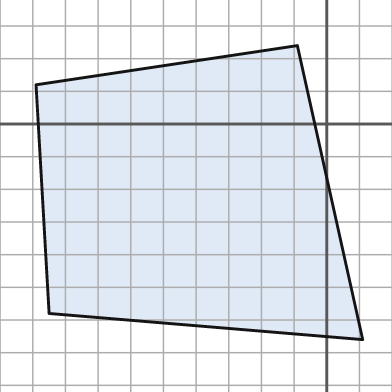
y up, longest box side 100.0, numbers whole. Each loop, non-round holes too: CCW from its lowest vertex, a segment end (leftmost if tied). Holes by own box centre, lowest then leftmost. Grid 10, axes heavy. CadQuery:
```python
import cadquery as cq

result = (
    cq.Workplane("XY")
    .moveTo(11.0, -66.0)
    .lineTo(-9.0, 24.0)
    .lineTo(-89.0, 12.0)
    .lineTo(-85.0, -58.0)
    .close()
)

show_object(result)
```